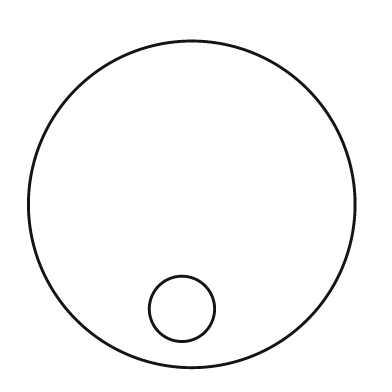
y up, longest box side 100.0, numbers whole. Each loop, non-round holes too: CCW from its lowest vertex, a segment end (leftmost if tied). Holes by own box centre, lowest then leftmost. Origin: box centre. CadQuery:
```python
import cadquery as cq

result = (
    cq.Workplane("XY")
    .moveTo(0.0, 0.0)
    .circle(50.0)
    .moveTo(-3.0, -32.0)
    .circle(10.0)
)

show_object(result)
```